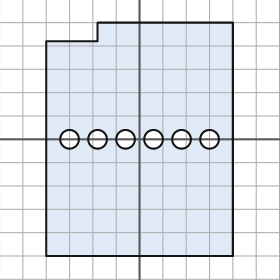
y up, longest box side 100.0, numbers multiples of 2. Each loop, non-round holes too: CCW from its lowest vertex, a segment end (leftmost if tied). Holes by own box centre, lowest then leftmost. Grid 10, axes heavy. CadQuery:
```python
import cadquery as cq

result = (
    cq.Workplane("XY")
    .moveTo(-40.0, -50.0)
    .lineTo(40.0, -50.0)
    .lineTo(40.0, 50.0)
    .lineTo(-18.0, 50.0)
    .lineTo(-18.0, 42.0)
    .lineTo(-40.0, 42.0)
    .close()
    .moveTo(-30.0, 0.0)
    .circle(4.0)
    .moveTo(-18.0, 0.0)
    .circle(4.0)
    .moveTo(-6.0, 0.0)
    .circle(4.0)
    .moveTo(6.0, 0.0)
    .circle(4.0)
    .moveTo(18.0, 0.0)
    .circle(4.0)
    .moveTo(30.0, 0.0)
    .circle(4.0)
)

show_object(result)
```